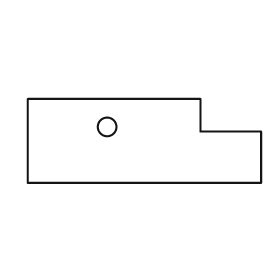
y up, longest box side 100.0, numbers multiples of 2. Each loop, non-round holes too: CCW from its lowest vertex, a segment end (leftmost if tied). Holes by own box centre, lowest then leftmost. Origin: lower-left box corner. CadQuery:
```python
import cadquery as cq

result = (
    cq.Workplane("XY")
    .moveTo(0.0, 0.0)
    .lineTo(100.0, 0.0)
    .lineTo(100.0, 22.0)
    .lineTo(74.0, 22.0)
    .lineTo(74.0, 36.0)
    .lineTo(0.0, 36.0)
    .close()
    .moveTo(34.0, 24.0)
    .circle(4.0)
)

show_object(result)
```